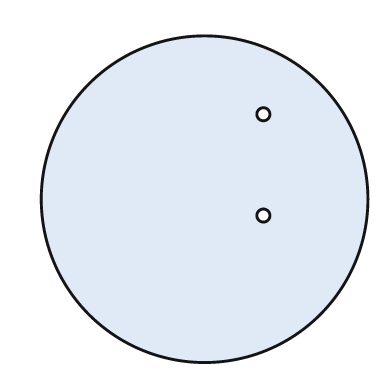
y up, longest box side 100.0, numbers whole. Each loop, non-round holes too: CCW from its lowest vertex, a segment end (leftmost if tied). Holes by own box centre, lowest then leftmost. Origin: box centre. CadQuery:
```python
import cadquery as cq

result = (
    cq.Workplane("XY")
    .moveTo(0.0, 0.0)
    .circle(50.0)
    .moveTo(18.0, -5.0)
    .circle(2.0)
    .moveTo(18.0, 26.0)
    .circle(2.0)
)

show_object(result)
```